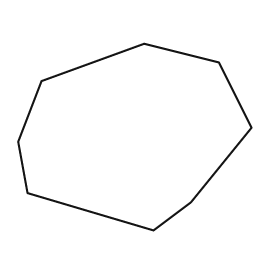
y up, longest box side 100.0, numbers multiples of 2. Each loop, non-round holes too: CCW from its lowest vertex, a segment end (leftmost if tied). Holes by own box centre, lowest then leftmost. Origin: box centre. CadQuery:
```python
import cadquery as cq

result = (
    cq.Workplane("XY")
    .moveTo(8.0, -40.0)
    .lineTo(24.0, -28.0)
    .lineTo(50.0, 4.0)
    .lineTo(36.0, 32.0)
    .lineTo(4.0, 40.0)
    .lineTo(-40.0, 24.0)
    .lineTo(-50.0, -2.0)
    .lineTo(-46.0, -24.0)
    .close()
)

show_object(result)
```